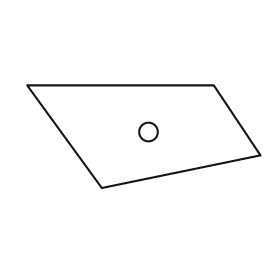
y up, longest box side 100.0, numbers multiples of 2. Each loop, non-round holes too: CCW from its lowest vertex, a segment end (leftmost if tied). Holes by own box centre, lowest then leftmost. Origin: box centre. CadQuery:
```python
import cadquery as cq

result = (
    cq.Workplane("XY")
    .moveTo(-18.0, -22.0)
    .lineTo(50.0, -8.0)
    .lineTo(30.0, 22.0)
    .lineTo(-50.0, 22.0)
    .close()
    .moveTo(2.0, 2.0)
    .circle(4.0)
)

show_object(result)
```